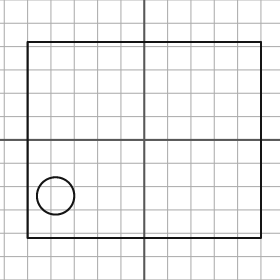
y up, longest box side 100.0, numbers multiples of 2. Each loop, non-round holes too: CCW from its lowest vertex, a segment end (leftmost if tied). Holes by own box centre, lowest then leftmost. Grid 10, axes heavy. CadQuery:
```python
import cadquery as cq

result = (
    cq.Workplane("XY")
    .moveTo(-50.0, -42.0)
    .lineTo(50.0, -42.0)
    .lineTo(50.0, 42.0)
    .lineTo(-50.0, 42.0)
    .close()
    .moveTo(-38.0, -24.0)
    .circle(8.0)
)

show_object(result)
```